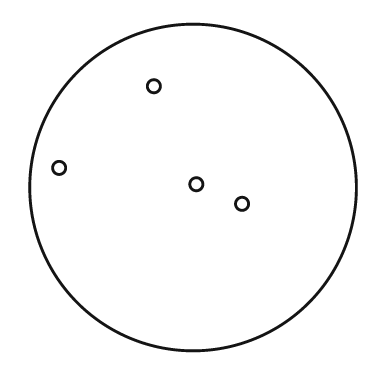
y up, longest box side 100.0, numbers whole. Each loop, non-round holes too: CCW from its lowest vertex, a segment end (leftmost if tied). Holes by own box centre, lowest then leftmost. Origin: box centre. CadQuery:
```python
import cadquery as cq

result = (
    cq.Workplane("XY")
    .moveTo(0.0, 0.0)
    .circle(50.0)
    .moveTo(15.0, -5.0)
    .circle(2.0)
    .moveTo(1.0, 1.0)
    .circle(2.0)
    .moveTo(-41.0, 6.0)
    .circle(2.0)
    .moveTo(-12.0, 31.0)
    .circle(2.0)
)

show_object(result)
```